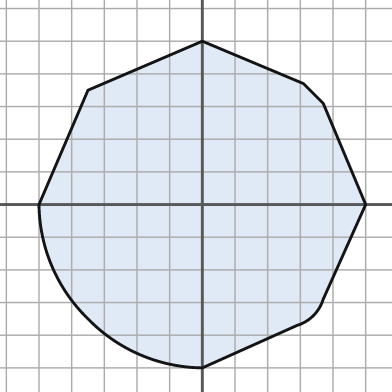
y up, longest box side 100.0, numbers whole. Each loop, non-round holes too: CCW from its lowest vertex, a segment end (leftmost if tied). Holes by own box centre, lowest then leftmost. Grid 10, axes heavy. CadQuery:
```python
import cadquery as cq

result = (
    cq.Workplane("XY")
    .moveTo(0.0, -50.0)
    .lineTo(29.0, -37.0)
    .threePointArc((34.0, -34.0), (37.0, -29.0))
    .lineTo(50.0, 0.0)
    .lineTo(37.0, 31.0)
    .lineTo(31.0, 37.0)
    .lineTo(0.0, 50.0)
    .lineTo(-35.0, 35.0)
    .lineTo(-50.0, 0.0)
    .threePointArc((-46.0, -19.0), (-35.0, -35.0))
    .threePointArc((-19.0, -46.0), (0.0, -50.0))
    .close()
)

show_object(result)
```